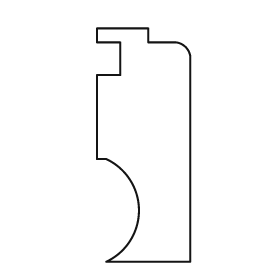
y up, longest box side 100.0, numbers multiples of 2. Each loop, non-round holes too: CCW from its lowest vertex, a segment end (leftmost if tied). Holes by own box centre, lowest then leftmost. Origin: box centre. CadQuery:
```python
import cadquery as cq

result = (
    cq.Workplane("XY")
    .moveTo(-16.0, -50.0)
    .lineTo(20.0, -50.0)
    .lineTo(20.0, 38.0)
    .threePointArc((18.0, 42.0), (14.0, 44.0))
    .lineTo(2.0, 44.0)
    .lineTo(2.0, 50.0)
    .lineTo(-20.0, 50.0)
    .lineTo(-20.0, 44.0)
    .lineTo(-10.0, 44.0)
    .lineTo(-10.0, 30.0)
    .lineTo(-20.0, 30.0)
    .lineTo(-20.0, -6.0)
    .lineTo(-16.0, -6.0)
    .threePointArc((-2.0, -28.0), (-16.0, -50.0))
    .close()
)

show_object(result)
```